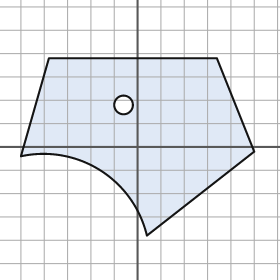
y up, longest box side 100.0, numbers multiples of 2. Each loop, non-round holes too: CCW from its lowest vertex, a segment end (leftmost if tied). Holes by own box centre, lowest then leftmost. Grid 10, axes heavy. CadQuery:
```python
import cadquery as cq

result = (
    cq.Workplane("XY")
    .moveTo(4.0, -38.0)
    .lineTo(50.0, -2.0)
    .lineTo(34.0, 38.0)
    .lineTo(-38.0, 38.0)
    .lineTo(-50.0, -4.0)
    .threePointArc((-16.0, -10.0), (4.0, -38.0))
    .close()
    .moveTo(-6.0, 18.0)
    .circle(4.0)
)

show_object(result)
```